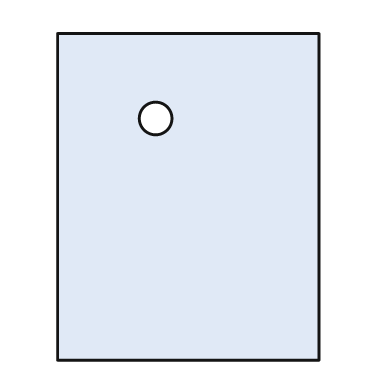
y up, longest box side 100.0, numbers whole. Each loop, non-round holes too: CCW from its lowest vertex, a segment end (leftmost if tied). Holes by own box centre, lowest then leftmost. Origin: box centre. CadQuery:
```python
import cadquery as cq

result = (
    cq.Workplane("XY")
    .moveTo(-40.0, -50.0)
    .lineTo(40.0, -50.0)
    .lineTo(40.0, 50.0)
    .lineTo(-40.0, 50.0)
    .close()
    .moveTo(-10.0, 24.0)
    .circle(5.0)
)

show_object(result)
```